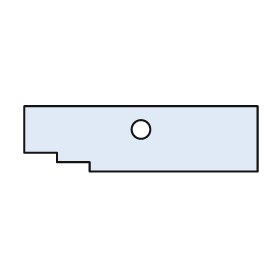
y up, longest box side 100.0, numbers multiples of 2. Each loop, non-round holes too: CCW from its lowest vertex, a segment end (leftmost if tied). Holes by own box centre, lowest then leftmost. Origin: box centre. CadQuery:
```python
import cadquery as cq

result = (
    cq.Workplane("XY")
    .moveTo(-22.0, -14.0)
    .lineTo(50.0, -14.0)
    .lineTo(50.0, 14.0)
    .lineTo(-50.0, 14.0)
    .lineTo(-50.0, -6.0)
    .lineTo(-36.0, -6.0)
    .lineTo(-36.0, -10.0)
    .lineTo(-22.0, -10.0)
    .close()
    .moveTo(0.0, 4.0)
    .circle(4.0)
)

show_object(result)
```